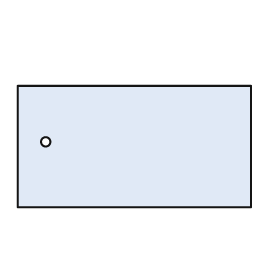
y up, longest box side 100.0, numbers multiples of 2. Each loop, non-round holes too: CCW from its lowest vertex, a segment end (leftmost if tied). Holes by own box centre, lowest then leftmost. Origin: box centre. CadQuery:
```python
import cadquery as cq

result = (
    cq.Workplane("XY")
    .moveTo(-50.0, -26.0)
    .lineTo(50.0, -26.0)
    .lineTo(50.0, 26.0)
    .lineTo(-50.0, 26.0)
    .close()
    .moveTo(-38.0, 2.0)
    .circle(2.0)
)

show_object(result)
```